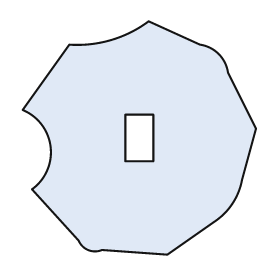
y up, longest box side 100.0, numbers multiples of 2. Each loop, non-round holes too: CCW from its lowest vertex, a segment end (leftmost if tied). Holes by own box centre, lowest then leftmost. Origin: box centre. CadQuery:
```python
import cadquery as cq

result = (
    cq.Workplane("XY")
    .moveTo(12.0, -50.0)
    .lineTo(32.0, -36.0)
    .threePointArc((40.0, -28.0), (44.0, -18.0))
    .lineTo(50.0, 4.0)
    .lineTo(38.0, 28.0)
    .threePointArc((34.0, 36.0), (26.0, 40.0))
    .lineTo(4.0, 50.0)
    .threePointArc((-12.0, 42.0), (-30.0, 40.0))
    .lineTo(-50.0, 12.0)
    .threePointArc((-38.0, -4.0), (-46.0, -22.0))
    .lineTo(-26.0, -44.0)
    .threePointArc((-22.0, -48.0), (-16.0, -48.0))
    .close()
    .moveTo(-6.0, -10.0)
    .lineTo(6.0, -10.0)
    .lineTo(6.0, 10.0)
    .lineTo(-6.0, 10.0)
    .close()
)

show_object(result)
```